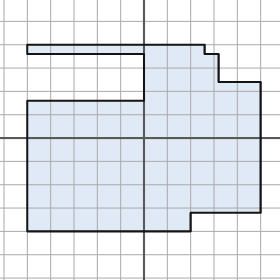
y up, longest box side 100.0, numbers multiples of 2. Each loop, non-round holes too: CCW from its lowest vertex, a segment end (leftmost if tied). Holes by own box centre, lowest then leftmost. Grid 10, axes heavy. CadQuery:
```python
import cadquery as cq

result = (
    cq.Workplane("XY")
    .moveTo(-50.0, -40.0)
    .lineTo(20.0, -40.0)
    .lineTo(20.0, -32.0)
    .lineTo(50.0, -32.0)
    .lineTo(50.0, 24.0)
    .lineTo(32.0, 24.0)
    .lineTo(32.0, 36.0)
    .lineTo(26.0, 36.0)
    .lineTo(26.0, 40.0)
    .lineTo(-50.0, 40.0)
    .lineTo(-50.0, 36.0)
    .lineTo(0.0, 36.0)
    .lineTo(0.0, 16.0)
    .lineTo(-50.0, 16.0)
    .close()
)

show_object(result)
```